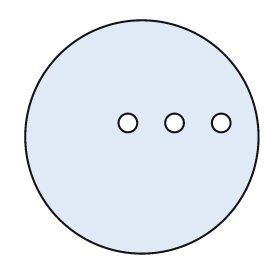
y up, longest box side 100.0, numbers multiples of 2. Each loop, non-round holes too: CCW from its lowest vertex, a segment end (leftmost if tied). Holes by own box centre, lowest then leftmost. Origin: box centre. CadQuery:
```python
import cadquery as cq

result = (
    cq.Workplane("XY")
    .moveTo(0.0, 0.0)
    .circle(50.0)
    .moveTo(-6.0, 6.0)
    .circle(4.0)
    .moveTo(14.0, 6.0)
    .circle(4.0)
    .moveTo(34.0, 6.0)
    .circle(4.0)
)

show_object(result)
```